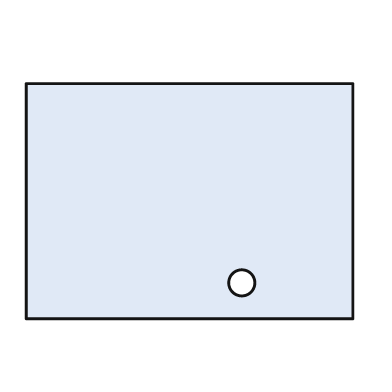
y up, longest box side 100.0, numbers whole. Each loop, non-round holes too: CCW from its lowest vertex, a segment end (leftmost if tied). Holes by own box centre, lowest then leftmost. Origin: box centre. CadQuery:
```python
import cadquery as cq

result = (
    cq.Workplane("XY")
    .moveTo(-50.0, -36.0)
    .lineTo(50.0, -36.0)
    .lineTo(50.0, 36.0)
    .lineTo(-50.0, 36.0)
    .close()
    .moveTo(16.0, -25.0)
    .circle(4.0)
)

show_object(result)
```